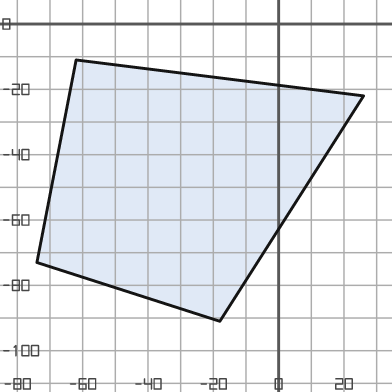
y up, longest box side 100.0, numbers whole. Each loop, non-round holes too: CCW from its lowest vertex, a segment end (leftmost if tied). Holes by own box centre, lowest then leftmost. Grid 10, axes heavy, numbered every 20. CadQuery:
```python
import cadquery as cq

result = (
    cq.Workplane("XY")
    .moveTo(-18.0, -91.0)
    .lineTo(26.0, -22.0)
    .lineTo(-62.0, -11.0)
    .lineTo(-74.0, -73.0)
    .close()
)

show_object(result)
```